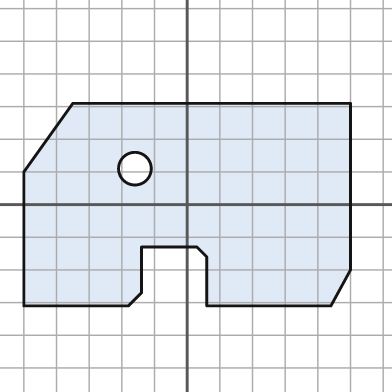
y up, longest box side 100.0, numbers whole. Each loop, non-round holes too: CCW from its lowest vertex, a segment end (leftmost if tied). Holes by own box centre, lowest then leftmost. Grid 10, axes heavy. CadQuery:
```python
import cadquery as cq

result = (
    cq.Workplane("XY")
    .moveTo(-50.0, -31.0)
    .lineTo(-18.0, -31.0)
    .lineTo(-14.0, -27.0)
    .lineTo(-14.0, -13.0)
    .lineTo(3.0, -13.0)
    .lineTo(6.0, -16.0)
    .lineTo(6.0, -31.0)
    .lineTo(44.0, -31.0)
    .lineTo(50.0, -20.0)
    .lineTo(50.0, 31.0)
    .lineTo(-35.0, 31.0)
    .lineTo(-50.0, 10.0)
    .close()
    .moveTo(-16.0, 11.0)
    .circle(5.0)
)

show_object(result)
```